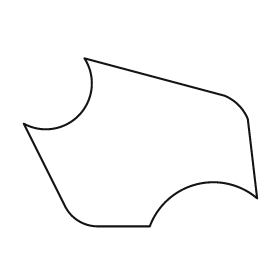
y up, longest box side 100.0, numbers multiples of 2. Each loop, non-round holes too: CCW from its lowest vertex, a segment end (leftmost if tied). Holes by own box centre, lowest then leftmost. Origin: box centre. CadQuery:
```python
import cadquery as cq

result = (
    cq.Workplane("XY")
    .moveTo(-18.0, -36.0)
    .lineTo(4.0, -36.0)
    .threePointArc((24.0, -18.0), (50.0, -24.0))
    .lineTo(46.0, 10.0)
    .threePointArc((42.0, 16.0), (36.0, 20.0))
    .lineTo(-24.0, 36.0)
    .threePointArc((-26.0, 12.0), (-50.0, 8.0))
    .lineTo(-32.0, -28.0)
    .threePointArc((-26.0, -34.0), (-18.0, -36.0))
    .close()
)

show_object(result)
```